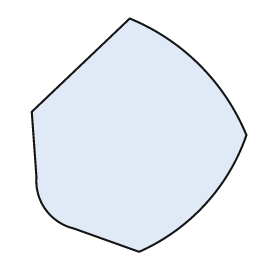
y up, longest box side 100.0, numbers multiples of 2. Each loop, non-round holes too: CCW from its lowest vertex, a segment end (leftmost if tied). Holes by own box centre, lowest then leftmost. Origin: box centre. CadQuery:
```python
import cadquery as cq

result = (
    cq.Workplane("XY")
    .moveTo(0.0, -50.0)
    .threePointArc((28.0, -30.0), (46.0, 0.0))
    .threePointArc((26.0, 30.0), (-4.0, 50.0))
    .lineTo(-46.0, 10.0)
    .lineTo(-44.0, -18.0)
    .threePointArc((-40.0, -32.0), (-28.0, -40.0))
    .close()
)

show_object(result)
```